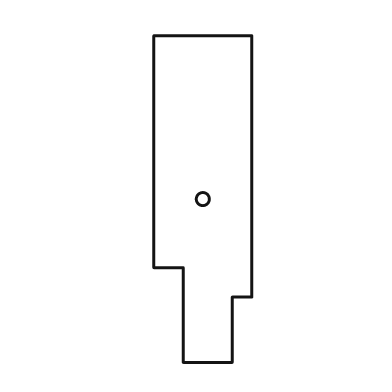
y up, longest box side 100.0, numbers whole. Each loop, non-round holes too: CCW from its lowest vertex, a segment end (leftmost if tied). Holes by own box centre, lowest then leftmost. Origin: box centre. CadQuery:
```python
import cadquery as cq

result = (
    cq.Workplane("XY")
    .moveTo(-6.0, -50.0)
    .lineTo(9.0, -50.0)
    .lineTo(9.0, -30.0)
    .lineTo(15.0, -30.0)
    .lineTo(15.0, 50.0)
    .lineTo(-15.0, 50.0)
    .lineTo(-15.0, -21.0)
    .lineTo(-6.0, -21.0)
    .close()
    .moveTo(0.0, 0.0)
    .circle(2.0)
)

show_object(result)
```